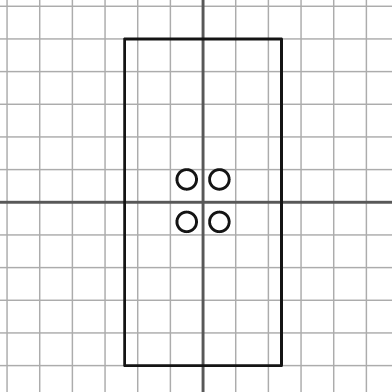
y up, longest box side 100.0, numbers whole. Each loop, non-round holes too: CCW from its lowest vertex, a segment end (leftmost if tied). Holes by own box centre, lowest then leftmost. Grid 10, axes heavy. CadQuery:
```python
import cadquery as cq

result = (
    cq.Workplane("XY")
    .moveTo(-24.0, -50.0)
    .lineTo(24.0, -50.0)
    .lineTo(24.0, 50.0)
    .lineTo(-24.0, 50.0)
    .close()
    .moveTo(-5.0, -6.0)
    .circle(3.0)
    .moveTo(5.0, -6.0)
    .circle(3.0)
    .moveTo(-5.0, 7.0)
    .circle(3.0)
    .moveTo(5.0, 7.0)
    .circle(3.0)
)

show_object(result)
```